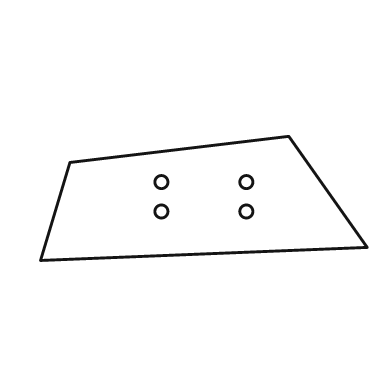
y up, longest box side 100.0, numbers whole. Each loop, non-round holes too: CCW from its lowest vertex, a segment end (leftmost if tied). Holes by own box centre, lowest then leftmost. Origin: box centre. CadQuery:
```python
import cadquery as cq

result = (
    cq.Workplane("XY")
    .moveTo(-50.0, -19.0)
    .lineTo(50.0, -15.0)
    .lineTo(26.0, 19.0)
    .lineTo(-41.0, 11.0)
    .close()
    .moveTo(-13.0, -4.0)
    .circle(2.0)
    .moveTo(13.0, -4.0)
    .circle(2.0)
    .moveTo(-13.0, 5.0)
    .circle(2.0)
    .moveTo(13.0, 5.0)
    .circle(2.0)
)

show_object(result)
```